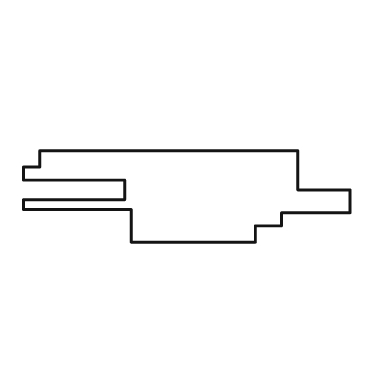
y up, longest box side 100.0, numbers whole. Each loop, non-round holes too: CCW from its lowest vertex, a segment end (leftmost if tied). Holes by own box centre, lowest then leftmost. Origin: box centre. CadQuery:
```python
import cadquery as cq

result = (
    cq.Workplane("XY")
    .moveTo(-17.0, -14.0)
    .lineTo(21.0, -14.0)
    .lineTo(21.0, -9.0)
    .lineTo(29.0, -9.0)
    .lineTo(29.0, -5.0)
    .lineTo(50.0, -5.0)
    .lineTo(50.0, 2.0)
    .lineTo(34.0, 2.0)
    .lineTo(34.0, 14.0)
    .lineTo(-45.0, 14.0)
    .lineTo(-45.0, 9.0)
    .lineTo(-50.0, 9.0)
    .lineTo(-50.0, 5.0)
    .lineTo(-19.0, 5.0)
    .lineTo(-19.0, -1.0)
    .lineTo(-50.0, -1.0)
    .lineTo(-50.0, -4.0)
    .lineTo(-17.0, -4.0)
    .close()
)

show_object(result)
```